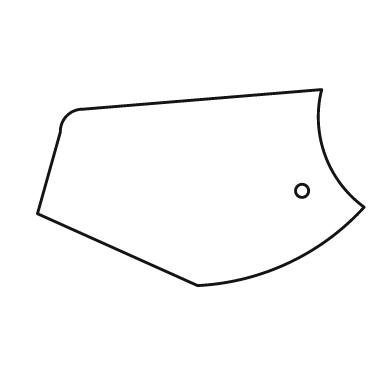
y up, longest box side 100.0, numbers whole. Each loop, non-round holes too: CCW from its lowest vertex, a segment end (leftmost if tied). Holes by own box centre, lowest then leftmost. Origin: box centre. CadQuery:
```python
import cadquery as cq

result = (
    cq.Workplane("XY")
    .moveTo(-1.0, -30.0)
    .threePointArc((27.0, -23.0), (50.0, -6.0))
    .threePointArc((38.0, 10.0), (37.0, 30.0))
    .lineTo(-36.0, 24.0)
    .threePointArc((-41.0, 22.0), (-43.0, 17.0))
    .lineTo(-50.0, -8.0)
    .close()
    .moveTo(31.0, -1.0)
    .circle(2.0)
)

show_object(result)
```